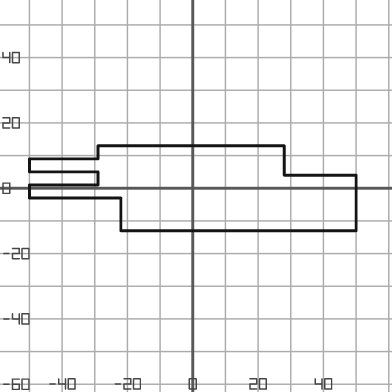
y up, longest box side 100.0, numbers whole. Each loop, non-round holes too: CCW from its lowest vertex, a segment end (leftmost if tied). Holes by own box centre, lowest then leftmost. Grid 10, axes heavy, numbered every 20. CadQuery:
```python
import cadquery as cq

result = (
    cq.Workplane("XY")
    .moveTo(-22.0, -13.0)
    .lineTo(50.0, -13.0)
    .lineTo(50.0, 4.0)
    .lineTo(28.0, 4.0)
    .lineTo(28.0, 13.0)
    .lineTo(-29.0, 13.0)
    .lineTo(-29.0, 9.0)
    .lineTo(-50.0, 9.0)
    .lineTo(-50.0, 5.0)
    .lineTo(-29.0, 5.0)
    .lineTo(-29.0, 1.0)
    .lineTo(-50.0, 1.0)
    .lineTo(-50.0, -3.0)
    .lineTo(-22.0, -3.0)
    .close()
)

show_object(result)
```